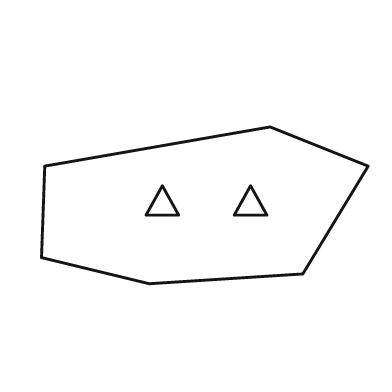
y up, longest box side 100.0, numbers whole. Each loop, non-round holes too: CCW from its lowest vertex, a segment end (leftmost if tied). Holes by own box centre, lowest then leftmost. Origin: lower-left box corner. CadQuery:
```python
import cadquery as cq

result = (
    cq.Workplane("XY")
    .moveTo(33.0, 0.0)
    .lineTo(80.0, 3.0)
    .lineTo(100.0, 36.0)
    .lineTo(70.0, 48.0)
    .lineTo(1.0, 36.0)
    .lineTo(0.0, 8.0)
    .close()
    .moveTo(32.0, 21.0)
    .lineTo(42.0, 21.0)
    .lineTo(37.0, 30.0)
    .close()
    .moveTo(59.0, 21.0)
    .lineTo(69.0, 21.0)
    .lineTo(64.0, 30.0)
    .close()
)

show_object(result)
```